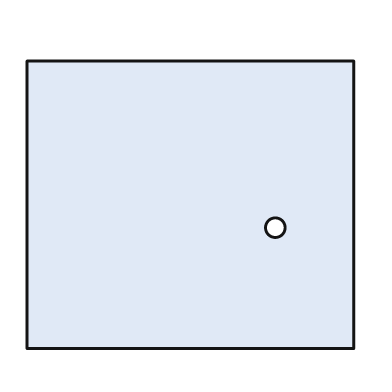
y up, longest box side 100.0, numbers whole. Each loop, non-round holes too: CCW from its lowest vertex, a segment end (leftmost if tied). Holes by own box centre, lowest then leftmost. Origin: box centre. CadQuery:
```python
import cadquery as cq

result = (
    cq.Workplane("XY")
    .moveTo(-50.0, -44.0)
    .lineTo(50.0, -44.0)
    .lineTo(50.0, 44.0)
    .lineTo(-50.0, 44.0)
    .close()
    .moveTo(26.0, -7.0)
    .circle(3.0)
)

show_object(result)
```